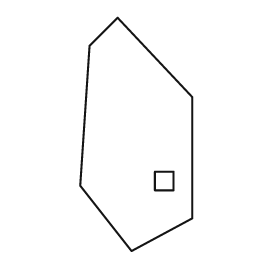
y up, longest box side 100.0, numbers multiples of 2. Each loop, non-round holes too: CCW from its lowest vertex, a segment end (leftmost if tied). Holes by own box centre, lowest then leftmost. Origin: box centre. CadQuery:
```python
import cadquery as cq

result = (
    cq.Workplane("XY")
    .moveTo(-2.0, -50.0)
    .lineTo(24.0, -36.0)
    .lineTo(24.0, 16.0)
    .lineTo(-8.0, 50.0)
    .lineTo(-20.0, 38.0)
    .lineTo(-24.0, -22.0)
    .close()
    .moveTo(8.0, -24.0)
    .lineTo(16.0, -24.0)
    .lineTo(16.0, -16.0)
    .lineTo(8.0, -16.0)
    .close()
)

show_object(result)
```